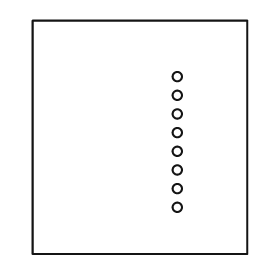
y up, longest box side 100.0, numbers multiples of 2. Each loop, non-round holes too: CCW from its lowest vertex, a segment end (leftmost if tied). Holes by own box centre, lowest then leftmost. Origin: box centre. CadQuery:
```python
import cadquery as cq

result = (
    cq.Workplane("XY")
    .moveTo(-46.0, -50.0)
    .lineTo(46.0, -50.0)
    .lineTo(46.0, 50.0)
    .lineTo(-46.0, 50.0)
    .close()
    .moveTo(16.0, -30.0)
    .circle(2.0)
    .moveTo(16.0, -22.0)
    .circle(2.0)
    .moveTo(16.0, -14.0)
    .circle(2.0)
    .moveTo(16.0, -6.0)
    .circle(2.0)
    .moveTo(16.0, 2.0)
    .circle(2.0)
    .moveTo(16.0, 10.0)
    .circle(2.0)
    .moveTo(16.0, 18.0)
    .circle(2.0)
    .moveTo(16.0, 26.0)
    .circle(2.0)
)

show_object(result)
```